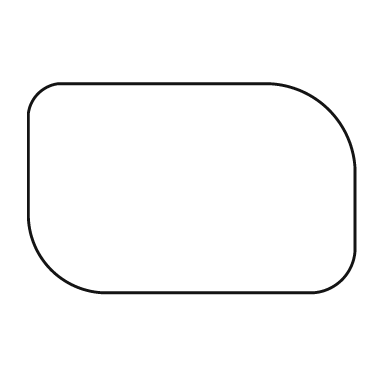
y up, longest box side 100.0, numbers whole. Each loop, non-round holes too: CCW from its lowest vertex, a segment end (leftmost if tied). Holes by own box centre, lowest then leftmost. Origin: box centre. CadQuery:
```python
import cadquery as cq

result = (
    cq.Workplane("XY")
    .moveTo(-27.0, -32.0)
    .lineTo(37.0, -32.0)
    .threePointArc((46.0, -28.0), (50.0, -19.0))
    .lineTo(50.0, 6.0)
    .threePointArc((42.0, 24.0), (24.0, 32.0))
    .lineTo(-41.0, 32.0)
    .threePointArc((-47.0, 29.0), (-50.0, 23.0))
    .lineTo(-50.0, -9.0)
    .threePointArc((-43.0, -25.0), (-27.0, -32.0))
    .close()
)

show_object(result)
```